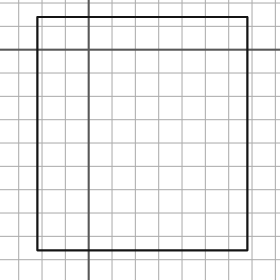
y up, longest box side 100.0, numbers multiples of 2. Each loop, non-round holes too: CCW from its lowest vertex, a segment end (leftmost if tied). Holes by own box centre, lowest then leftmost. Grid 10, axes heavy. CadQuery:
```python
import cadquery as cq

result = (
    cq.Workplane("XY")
    .moveTo(-22.0, -86.0)
    .lineTo(68.0, -86.0)
    .lineTo(68.0, 14.0)
    .lineTo(-22.0, 14.0)
    .close()
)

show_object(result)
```